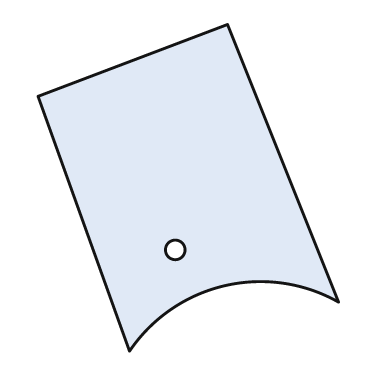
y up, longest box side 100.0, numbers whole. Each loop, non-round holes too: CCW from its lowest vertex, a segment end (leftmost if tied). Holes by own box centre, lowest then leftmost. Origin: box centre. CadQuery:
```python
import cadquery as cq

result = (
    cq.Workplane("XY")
    .moveTo(-18.0, -50.0)
    .threePointArc((11.0, -30.0), (46.0, -35.0))
    .lineTo(12.0, 50.0)
    .lineTo(-46.0, 28.0)
    .close()
    .moveTo(-4.0, -19.0)
    .circle(3.0)
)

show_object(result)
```